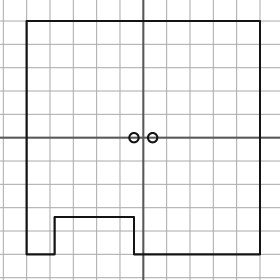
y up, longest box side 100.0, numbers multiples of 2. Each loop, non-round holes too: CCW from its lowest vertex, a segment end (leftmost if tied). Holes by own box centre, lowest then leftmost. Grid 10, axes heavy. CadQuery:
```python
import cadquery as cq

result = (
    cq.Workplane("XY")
    .moveTo(-50.0, -50.0)
    .lineTo(-38.0, -50.0)
    .lineTo(-38.0, -34.0)
    .lineTo(-4.0, -34.0)
    .lineTo(-4.0, -50.0)
    .lineTo(50.0, -50.0)
    .lineTo(50.0, 50.0)
    .lineTo(-50.0, 50.0)
    .close()
    .moveTo(-4.0, 0.0)
    .circle(2.0)
    .moveTo(4.0, 0.0)
    .circle(2.0)
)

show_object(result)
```